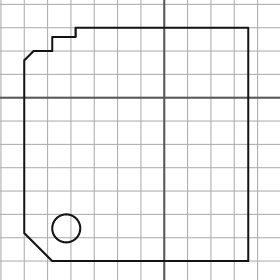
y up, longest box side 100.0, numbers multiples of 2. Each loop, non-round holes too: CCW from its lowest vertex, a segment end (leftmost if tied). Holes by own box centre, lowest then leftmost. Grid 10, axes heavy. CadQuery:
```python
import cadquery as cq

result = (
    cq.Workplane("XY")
    .moveTo(-48.0, -70.0)
    .lineTo(36.0, -70.0)
    .lineTo(36.0, 30.0)
    .lineTo(-38.0, 30.0)
    .lineTo(-38.0, 26.0)
    .lineTo(-48.0, 26.0)
    .lineTo(-48.0, 20.0)
    .lineTo(-56.0, 20.0)
    .lineTo(-60.0, 16.0)
    .lineTo(-60.0, -58.0)
    .close()
    .moveTo(-42.0, -56.0)
    .circle(6.0)
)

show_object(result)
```